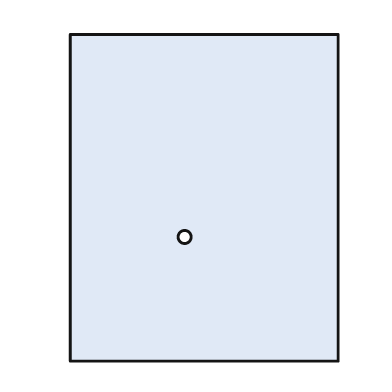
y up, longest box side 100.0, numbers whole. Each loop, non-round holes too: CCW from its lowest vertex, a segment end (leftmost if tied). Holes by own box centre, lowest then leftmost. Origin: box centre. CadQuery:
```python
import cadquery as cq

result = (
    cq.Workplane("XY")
    .moveTo(-41.0, -50.0)
    .lineTo(41.0, -50.0)
    .lineTo(41.0, 50.0)
    .lineTo(-41.0, 50.0)
    .close()
    .moveTo(-6.0, -12.0)
    .circle(2.0)
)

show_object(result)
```